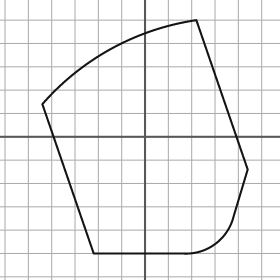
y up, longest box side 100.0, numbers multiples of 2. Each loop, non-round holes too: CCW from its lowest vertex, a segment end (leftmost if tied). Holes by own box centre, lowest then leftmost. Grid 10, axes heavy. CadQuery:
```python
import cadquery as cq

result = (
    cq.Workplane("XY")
    .moveTo(-22.0, -50.0)
    .lineTo(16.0, -50.0)
    .threePointArc((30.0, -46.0), (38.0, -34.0))
    .lineTo(44.0, -14.0)
    .lineTo(22.0, 50.0)
    .threePointArc((-14.0, 38.0), (-44.0, 14.0))
    .close()
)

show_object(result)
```